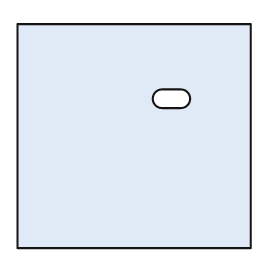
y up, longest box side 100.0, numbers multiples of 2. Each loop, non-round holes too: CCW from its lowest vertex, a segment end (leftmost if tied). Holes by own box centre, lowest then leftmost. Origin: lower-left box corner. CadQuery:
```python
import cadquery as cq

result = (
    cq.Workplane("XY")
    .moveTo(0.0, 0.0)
    .lineTo(100.0, 0.0)
    .lineTo(100.0, 96.0)
    .lineTo(0.0, 96.0)
    .close()
    .moveTo(62.0, 60.0)
    .lineTo(70.0, 60.0)
    .threePointArc((74.0, 64.0), (70.0, 68.0))
    .lineTo(62.0, 68.0)
    .threePointArc((58.0, 64.0), (62.0, 60.0))
    .close()
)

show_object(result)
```